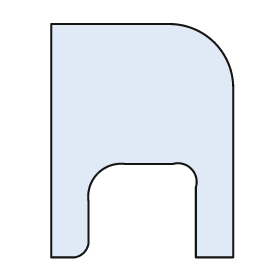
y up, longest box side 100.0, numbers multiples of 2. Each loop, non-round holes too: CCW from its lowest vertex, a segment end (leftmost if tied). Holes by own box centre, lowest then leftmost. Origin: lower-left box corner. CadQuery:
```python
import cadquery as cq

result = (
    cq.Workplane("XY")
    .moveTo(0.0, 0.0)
    .lineTo(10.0, 0.0)
    .threePointArc((14.0, 2.0), (16.0, 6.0))
    .lineTo(16.0, 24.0)
    .threePointArc((20.0, 36.0), (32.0, 40.0))
    .lineTo(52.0, 40.0)
    .threePointArc((60.0, 38.0), (62.0, 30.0))
    .lineTo(62.0, 0.0)
    .lineTo(78.0, 0.0)
    .lineTo(78.0, 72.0)
    .threePointArc((70.0, 92.0), (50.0, 100.0))
    .lineTo(0.0, 100.0)
    .close()
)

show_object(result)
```